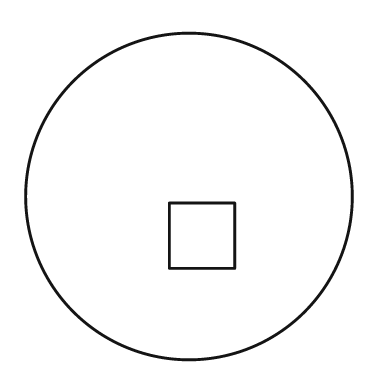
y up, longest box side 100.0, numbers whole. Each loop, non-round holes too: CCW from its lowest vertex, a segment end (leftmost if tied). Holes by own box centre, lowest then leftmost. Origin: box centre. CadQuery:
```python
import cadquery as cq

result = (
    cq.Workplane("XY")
    .moveTo(0.0, 0.0)
    .circle(50.0)
    .moveTo(-6.0, -22.0)
    .lineTo(14.0, -22.0)
    .lineTo(14.0, -2.0)
    .lineTo(-6.0, -2.0)
    .close()
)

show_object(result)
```